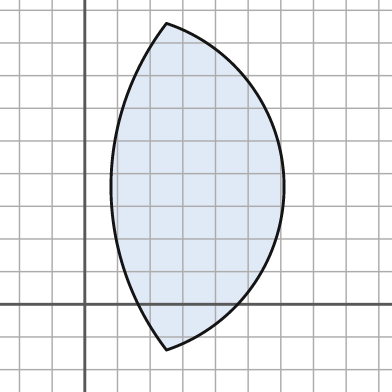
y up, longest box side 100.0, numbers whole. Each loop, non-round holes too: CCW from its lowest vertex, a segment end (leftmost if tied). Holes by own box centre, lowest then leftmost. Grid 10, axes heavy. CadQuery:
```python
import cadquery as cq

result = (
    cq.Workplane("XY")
    .moveTo(25.0, -14.0)
    .threePointArc((61.0, 36.0), (25.0, 86.0))
    .threePointArc((8.0, 36.0), (25.0, -14.0))
    .close()
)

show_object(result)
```